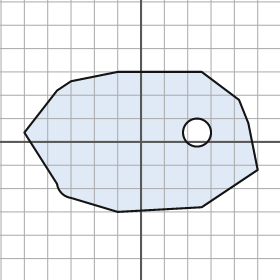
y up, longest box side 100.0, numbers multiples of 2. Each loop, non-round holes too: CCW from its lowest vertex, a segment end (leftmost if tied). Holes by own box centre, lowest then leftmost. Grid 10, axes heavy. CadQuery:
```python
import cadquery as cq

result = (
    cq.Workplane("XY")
    .moveTo(-10.0, -30.0)
    .lineTo(26.0, -28.0)
    .lineTo(50.0, -12.0)
    .lineTo(46.0, 8.0)
    .lineTo(42.0, 18.0)
    .lineTo(26.0, 30.0)
    .lineTo(-10.0, 30.0)
    .lineTo(-30.0, 26.0)
    .lineTo(-36.0, 22.0)
    .lineTo(-50.0, 4.0)
    .lineTo(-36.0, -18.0)
    .threePointArc((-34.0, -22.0), (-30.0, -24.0))
    .close()
    .moveTo(24.0, 4.0)
    .circle(6.0)
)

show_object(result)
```